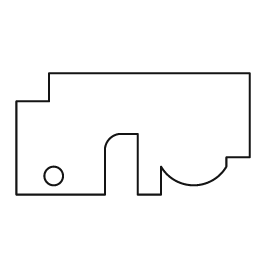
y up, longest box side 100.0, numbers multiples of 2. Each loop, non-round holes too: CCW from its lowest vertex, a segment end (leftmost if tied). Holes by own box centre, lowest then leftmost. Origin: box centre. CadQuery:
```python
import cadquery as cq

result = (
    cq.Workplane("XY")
    .moveTo(-50.0, -26.0)
    .lineTo(-12.0, -26.0)
    .lineTo(-12.0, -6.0)
    .threePointArc((-10.0, -2.0), (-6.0, 0.0))
    .lineTo(2.0, 0.0)
    .lineTo(2.0, -26.0)
    .lineTo(12.0, -26.0)
    .lineTo(12.0, -14.0)
    .threePointArc((26.0, -22.0), (40.0, -14.0))
    .lineTo(40.0, -10.0)
    .lineTo(50.0, -10.0)
    .lineTo(50.0, 26.0)
    .lineTo(-36.0, 26.0)
    .lineTo(-36.0, 14.0)
    .lineTo(-50.0, 14.0)
    .close()
    .moveTo(-34.0, -18.0)
    .circle(4.0)
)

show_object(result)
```